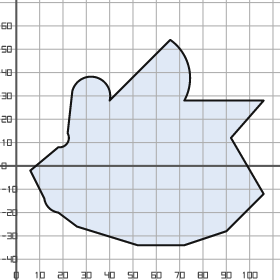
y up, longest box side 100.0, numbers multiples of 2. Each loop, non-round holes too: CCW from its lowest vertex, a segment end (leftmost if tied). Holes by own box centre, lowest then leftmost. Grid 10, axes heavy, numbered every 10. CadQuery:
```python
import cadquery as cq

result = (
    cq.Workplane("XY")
    .moveTo(52.0, -34.0)
    .lineTo(72.0, -34.0)
    .lineTo(90.0, -28.0)
    .lineTo(106.0, -12.0)
    .lineTo(92.0, 12.0)
    .lineTo(106.0, 28.0)
    .lineTo(72.0, 28.0)
    .threePointArc((74.0, 42.0), (66.0, 54.0))
    .lineTo(40.0, 28.0)
    .threePointArc((34.0, 38.0), (24.0, 32.0))
    .lineTo(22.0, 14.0)
    .threePointArc((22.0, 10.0), (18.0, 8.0))
    .lineTo(6.0, -2.0)
    .lineTo(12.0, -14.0)
    .threePointArc((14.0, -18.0), (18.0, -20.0))
    .lineTo(26.0, -26.0)
    .close()
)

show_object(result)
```